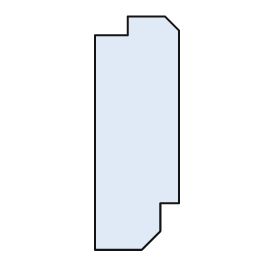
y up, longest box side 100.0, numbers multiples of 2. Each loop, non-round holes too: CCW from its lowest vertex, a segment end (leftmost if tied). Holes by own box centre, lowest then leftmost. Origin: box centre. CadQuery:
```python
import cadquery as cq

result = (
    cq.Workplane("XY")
    .moveTo(-18.0, -50.0)
    .lineTo(2.0, -50.0)
    .lineTo(10.0, -42.0)
    .lineTo(10.0, -30.0)
    .lineTo(18.0, -30.0)
    .lineTo(18.0, 44.0)
    .lineTo(12.0, 50.0)
    .lineTo(-4.0, 50.0)
    .lineTo(-4.0, 42.0)
    .lineTo(-18.0, 42.0)
    .close()
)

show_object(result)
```